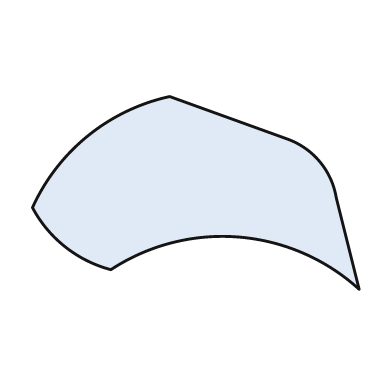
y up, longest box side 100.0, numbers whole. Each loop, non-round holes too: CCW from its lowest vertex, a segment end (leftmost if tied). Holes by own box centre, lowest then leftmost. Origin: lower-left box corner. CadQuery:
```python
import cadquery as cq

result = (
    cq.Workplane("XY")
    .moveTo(100.0, 0.0)
    .lineTo(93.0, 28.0)
    .threePointArc((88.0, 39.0), (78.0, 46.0))
    .lineTo(42.0, 59.0)
    .threePointArc((17.0, 47.0), (0.0, 25.0))
    .threePointArc((10.0, 13.0), (24.0, 6.0))
    .threePointArc((63.0, 16.0), (100.0, 0.0))
    .close()
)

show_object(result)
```